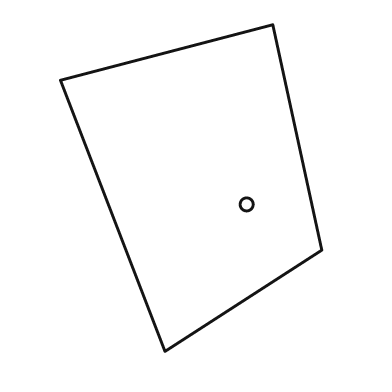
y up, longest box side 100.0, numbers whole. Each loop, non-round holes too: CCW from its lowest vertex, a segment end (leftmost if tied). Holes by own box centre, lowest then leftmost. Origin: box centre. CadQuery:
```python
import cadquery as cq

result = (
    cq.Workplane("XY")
    .moveTo(-8.0, -50.0)
    .lineTo(40.0, -19.0)
    .lineTo(25.0, 50.0)
    .lineTo(-40.0, 33.0)
    .close()
    .moveTo(17.0, -5.0)
    .circle(2.0)
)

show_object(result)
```